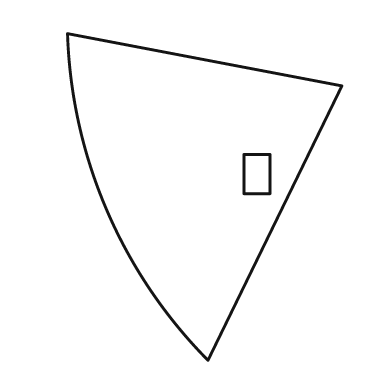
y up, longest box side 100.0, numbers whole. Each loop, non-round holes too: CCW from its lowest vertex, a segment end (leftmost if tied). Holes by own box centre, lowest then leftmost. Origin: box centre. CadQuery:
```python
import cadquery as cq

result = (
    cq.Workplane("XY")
    .moveTo(1.0, -50.0)
    .lineTo(42.0, 34.0)
    .lineTo(-42.0, 50.0)
    .threePointArc((-30.0, -4.0), (1.0, -50.0))
    .close()
    .moveTo(12.0, 1.0)
    .lineTo(20.0, 1.0)
    .lineTo(20.0, 13.0)
    .lineTo(12.0, 13.0)
    .close()
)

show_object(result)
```